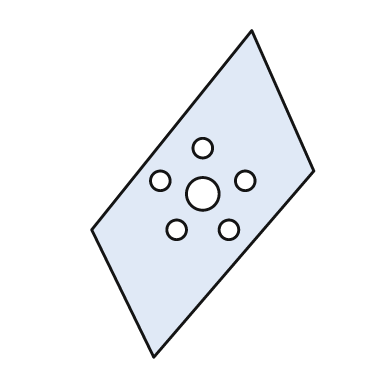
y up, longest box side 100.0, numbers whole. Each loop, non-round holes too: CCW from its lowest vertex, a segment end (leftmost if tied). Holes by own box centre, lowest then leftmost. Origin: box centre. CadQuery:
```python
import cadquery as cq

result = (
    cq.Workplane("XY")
    .moveTo(-15.0, -50.0)
    .lineTo(34.0, 7.0)
    .lineTo(15.0, 50.0)
    .lineTo(-34.0, -11.0)
    .close()
    .moveTo(-8.0, -11.0)
    .circle(3.0)
    .moveTo(8.0, -11.0)
    .circle(3.0)
    .moveTo(0.0, 0.0)
    .circle(5.0)
    .moveTo(-13.0, 4.0)
    .circle(3.0)
    .moveTo(13.0, 4.0)
    .circle(3.0)
    .moveTo(0.0, 14.0)
    .circle(3.0)
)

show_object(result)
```